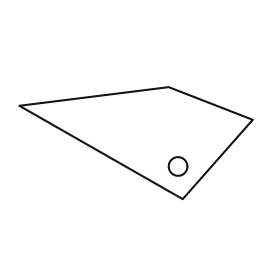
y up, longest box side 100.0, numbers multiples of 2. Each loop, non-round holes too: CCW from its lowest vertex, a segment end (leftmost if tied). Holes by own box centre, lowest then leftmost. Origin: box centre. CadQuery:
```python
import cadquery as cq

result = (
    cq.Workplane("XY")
    .moveTo(20.0, -24.0)
    .lineTo(50.0, 10.0)
    .lineTo(14.0, 24.0)
    .lineTo(-50.0, 16.0)
    .close()
    .moveTo(18.0, -10.0)
    .circle(4.0)
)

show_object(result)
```